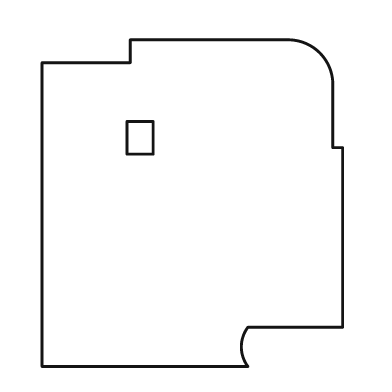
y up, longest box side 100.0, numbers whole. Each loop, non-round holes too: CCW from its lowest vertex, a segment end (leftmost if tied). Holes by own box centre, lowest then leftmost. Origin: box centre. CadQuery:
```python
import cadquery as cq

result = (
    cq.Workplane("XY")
    .moveTo(-46.0, -50.0)
    .lineTo(17.0, -50.0)
    .threePointArc((15.0, -44.0), (17.0, -38.0))
    .lineTo(46.0, -38.0)
    .lineTo(46.0, 17.0)
    .lineTo(43.0, 17.0)
    .lineTo(43.0, 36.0)
    .threePointArc((39.0, 46.0), (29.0, 50.0))
    .lineTo(-19.0, 50.0)
    .lineTo(-19.0, 43.0)
    .lineTo(-46.0, 43.0)
    .close()
    .moveTo(-20.0, 15.0)
    .lineTo(-12.0, 15.0)
    .lineTo(-12.0, 25.0)
    .lineTo(-20.0, 25.0)
    .close()
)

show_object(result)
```